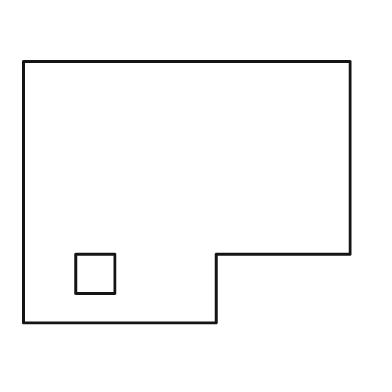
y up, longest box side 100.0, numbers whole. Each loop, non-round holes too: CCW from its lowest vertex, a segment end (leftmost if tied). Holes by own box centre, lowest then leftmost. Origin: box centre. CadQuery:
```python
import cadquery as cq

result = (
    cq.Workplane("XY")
    .moveTo(-50.0, -40.0)
    .lineTo(9.0, -40.0)
    .lineTo(9.0, -19.0)
    .lineTo(50.0, -19.0)
    .lineTo(50.0, 40.0)
    .lineTo(-50.0, 40.0)
    .close()
    .moveTo(-34.0, -31.0)
    .lineTo(-22.0, -31.0)
    .lineTo(-22.0, -19.0)
    .lineTo(-34.0, -19.0)
    .close()
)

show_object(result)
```